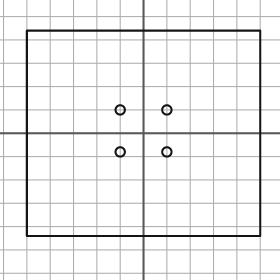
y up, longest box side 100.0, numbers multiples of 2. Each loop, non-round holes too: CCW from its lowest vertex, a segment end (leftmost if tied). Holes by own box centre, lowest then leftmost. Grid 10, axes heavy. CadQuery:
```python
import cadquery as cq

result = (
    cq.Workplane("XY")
    .moveTo(-50.0, -44.0)
    .lineTo(50.0, -44.0)
    .lineTo(50.0, 44.0)
    .lineTo(-50.0, 44.0)
    .close()
    .moveTo(-10.0, -8.0)
    .circle(2.0)
    .moveTo(10.0, -8.0)
    .circle(2.0)
    .moveTo(-10.0, 10.0)
    .circle(2.0)
    .moveTo(10.0, 10.0)
    .circle(2.0)
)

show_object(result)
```